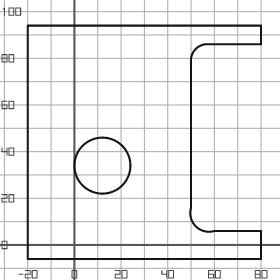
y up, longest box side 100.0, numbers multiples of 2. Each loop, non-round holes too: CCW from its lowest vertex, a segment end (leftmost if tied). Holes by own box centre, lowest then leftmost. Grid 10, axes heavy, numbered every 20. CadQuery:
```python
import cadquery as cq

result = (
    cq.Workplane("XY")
    .moveTo(-20.0, -6.0)
    .lineTo(80.0, -6.0)
    .lineTo(80.0, 6.0)
    .lineTo(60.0, 6.0)
    .threePointArc((52.0, 8.0), (50.0, 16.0))
    .lineTo(50.0, 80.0)
    .threePointArc((52.0, 84.0), (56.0, 86.0))
    .lineTo(80.0, 86.0)
    .lineTo(80.0, 94.0)
    .lineTo(-20.0, 94.0)
    .close()
    .moveTo(12.0, 34.0)
    .circle(12.0)
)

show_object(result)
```